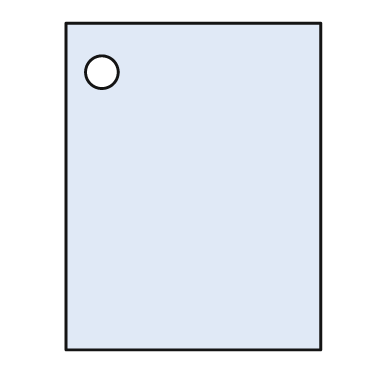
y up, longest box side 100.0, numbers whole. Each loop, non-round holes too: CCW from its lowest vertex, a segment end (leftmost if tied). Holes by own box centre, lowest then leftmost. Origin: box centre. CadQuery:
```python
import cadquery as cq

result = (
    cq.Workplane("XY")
    .moveTo(-39.0, -50.0)
    .lineTo(39.0, -50.0)
    .lineTo(39.0, 50.0)
    .lineTo(-39.0, 50.0)
    .close()
    .moveTo(-28.0, 35.0)
    .circle(5.0)
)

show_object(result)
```